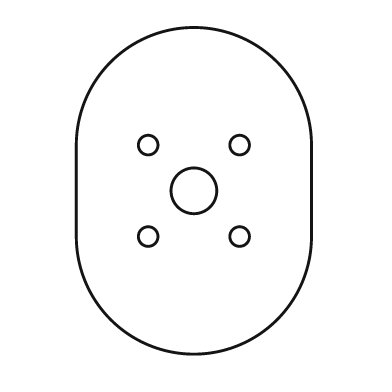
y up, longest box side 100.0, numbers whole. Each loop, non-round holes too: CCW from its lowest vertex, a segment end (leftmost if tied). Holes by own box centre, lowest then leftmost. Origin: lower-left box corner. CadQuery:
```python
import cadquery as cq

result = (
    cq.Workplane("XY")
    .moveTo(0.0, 36.0)
    .threePointArc((36.0, 0.0), (72.0, 36.0))
    .lineTo(72.0, 64.0)
    .threePointArc((36.0, 100.0), (0.0, 64.0))
    .close()
    .moveTo(22.0, 36.0)
    .circle(3.0)
    .moveTo(50.0, 36.0)
    .circle(3.0)
    .moveTo(36.0, 50.0)
    .circle(7.0)
    .moveTo(22.0, 64.0)
    .circle(3.0)
    .moveTo(50.0, 64.0)
    .circle(3.0)
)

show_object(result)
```